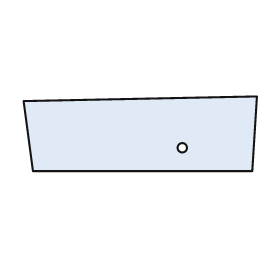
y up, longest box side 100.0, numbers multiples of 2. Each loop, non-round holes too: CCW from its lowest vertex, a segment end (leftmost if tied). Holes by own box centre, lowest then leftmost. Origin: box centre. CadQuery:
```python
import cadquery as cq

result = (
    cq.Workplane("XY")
    .moveTo(-46.0, -16.0)
    .lineTo(48.0, -16.0)
    .lineTo(50.0, 16.0)
    .lineTo(-50.0, 14.0)
    .close()
    .moveTo(18.0, -6.0)
    .circle(2.0)
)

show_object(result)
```